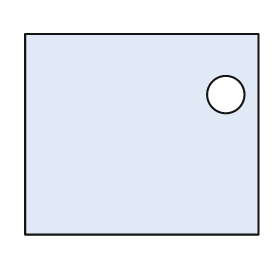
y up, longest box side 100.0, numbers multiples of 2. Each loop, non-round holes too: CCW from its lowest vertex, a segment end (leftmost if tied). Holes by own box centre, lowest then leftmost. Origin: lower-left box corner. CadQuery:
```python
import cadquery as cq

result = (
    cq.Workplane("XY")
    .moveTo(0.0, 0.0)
    .lineTo(100.0, 0.0)
    .lineTo(100.0, 86.0)
    .lineTo(0.0, 86.0)
    .close()
    .moveTo(86.0, 60.0)
    .circle(8.0)
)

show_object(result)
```